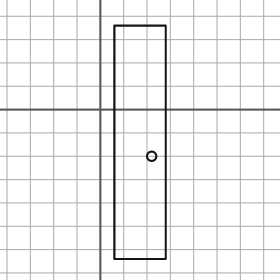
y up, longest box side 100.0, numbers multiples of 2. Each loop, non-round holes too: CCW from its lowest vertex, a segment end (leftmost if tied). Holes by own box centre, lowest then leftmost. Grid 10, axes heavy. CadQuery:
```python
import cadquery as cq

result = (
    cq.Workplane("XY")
    .moveTo(6.0, -64.0)
    .lineTo(28.0, -64.0)
    .lineTo(28.0, 36.0)
    .lineTo(6.0, 36.0)
    .close()
    .moveTo(22.0, -20.0)
    .circle(2.0)
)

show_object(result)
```